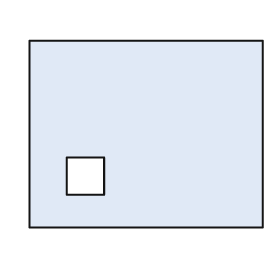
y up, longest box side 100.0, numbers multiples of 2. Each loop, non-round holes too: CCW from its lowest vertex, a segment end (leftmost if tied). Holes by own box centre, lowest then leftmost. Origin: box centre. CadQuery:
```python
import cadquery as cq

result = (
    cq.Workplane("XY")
    .moveTo(-50.0, -40.0)
    .lineTo(50.0, -40.0)
    .lineTo(50.0, 40.0)
    .lineTo(-50.0, 40.0)
    .close()
    .moveTo(-34.0, -26.0)
    .lineTo(-18.0, -26.0)
    .lineTo(-18.0, -10.0)
    .lineTo(-34.0, -10.0)
    .close()
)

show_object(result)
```